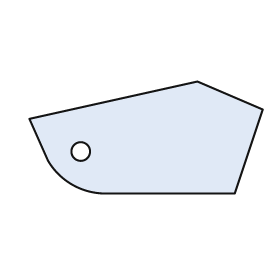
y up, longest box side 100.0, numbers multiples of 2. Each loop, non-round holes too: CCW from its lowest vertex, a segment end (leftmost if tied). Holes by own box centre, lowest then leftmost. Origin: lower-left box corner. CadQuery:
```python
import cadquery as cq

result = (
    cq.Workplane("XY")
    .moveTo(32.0, 0.0)
    .lineTo(88.0, 0.0)
    .lineTo(100.0, 36.0)
    .lineTo(72.0, 48.0)
    .lineTo(0.0, 32.0)
    .lineTo(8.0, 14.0)
    .threePointArc((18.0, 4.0), (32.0, 0.0))
    .close()
    .moveTo(22.0, 18.0)
    .circle(4.0)
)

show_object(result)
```